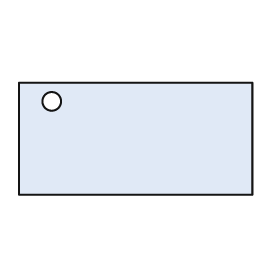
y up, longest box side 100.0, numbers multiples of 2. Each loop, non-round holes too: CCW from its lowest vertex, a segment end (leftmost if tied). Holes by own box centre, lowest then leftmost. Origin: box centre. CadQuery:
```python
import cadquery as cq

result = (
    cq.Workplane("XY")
    .moveTo(-50.0, -24.0)
    .lineTo(50.0, -24.0)
    .lineTo(50.0, 24.0)
    .lineTo(-50.0, 24.0)
    .close()
    .moveTo(-36.0, 16.0)
    .circle(4.0)
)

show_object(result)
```